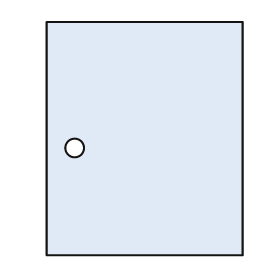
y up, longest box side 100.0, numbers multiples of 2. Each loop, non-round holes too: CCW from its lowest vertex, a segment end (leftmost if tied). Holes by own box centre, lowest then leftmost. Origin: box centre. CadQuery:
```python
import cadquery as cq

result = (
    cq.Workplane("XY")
    .moveTo(-42.0, -50.0)
    .lineTo(42.0, -50.0)
    .lineTo(42.0, 50.0)
    .lineTo(-42.0, 50.0)
    .close()
    .moveTo(-30.0, -4.0)
    .circle(4.0)
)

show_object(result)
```